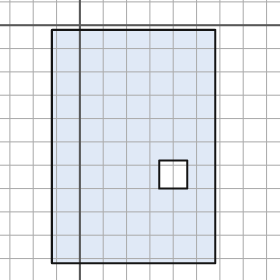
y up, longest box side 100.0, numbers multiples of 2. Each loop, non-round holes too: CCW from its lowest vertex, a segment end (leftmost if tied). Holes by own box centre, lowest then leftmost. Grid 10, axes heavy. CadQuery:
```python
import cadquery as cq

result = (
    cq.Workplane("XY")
    .moveTo(-12.0, -102.0)
    .lineTo(58.0, -102.0)
    .lineTo(58.0, -2.0)
    .lineTo(-12.0, -2.0)
    .close()
    .moveTo(34.0, -70.0)
    .lineTo(46.0, -70.0)
    .lineTo(46.0, -58.0)
    .lineTo(34.0, -58.0)
    .close()
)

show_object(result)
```